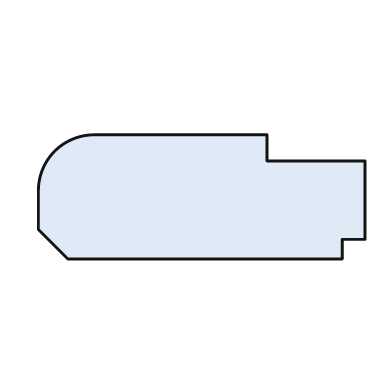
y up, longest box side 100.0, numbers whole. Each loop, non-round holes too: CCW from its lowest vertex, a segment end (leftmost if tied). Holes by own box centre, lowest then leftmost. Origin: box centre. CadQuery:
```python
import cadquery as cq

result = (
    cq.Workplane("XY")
    .moveTo(-41.0, -19.0)
    .lineTo(43.0, -19.0)
    .lineTo(43.0, -13.0)
    .lineTo(50.0, -13.0)
    .lineTo(50.0, 11.0)
    .lineTo(20.0, 11.0)
    .lineTo(20.0, 19.0)
    .lineTo(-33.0, 19.0)
    .threePointArc((-45.0, 14.0), (-50.0, 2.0))
    .lineTo(-50.0, -10.0)
    .close()
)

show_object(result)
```